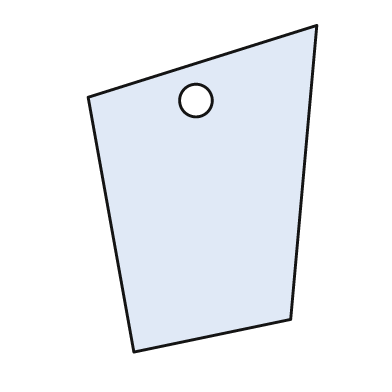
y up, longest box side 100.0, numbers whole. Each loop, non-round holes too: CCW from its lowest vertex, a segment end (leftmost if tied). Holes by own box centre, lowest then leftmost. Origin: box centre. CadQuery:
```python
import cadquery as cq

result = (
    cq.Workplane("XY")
    .moveTo(-21.0, -50.0)
    .lineTo(27.0, -40.0)
    .lineTo(35.0, 50.0)
    .lineTo(-35.0, 28.0)
    .close()
    .moveTo(-2.0, 27.0)
    .circle(5.0)
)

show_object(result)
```